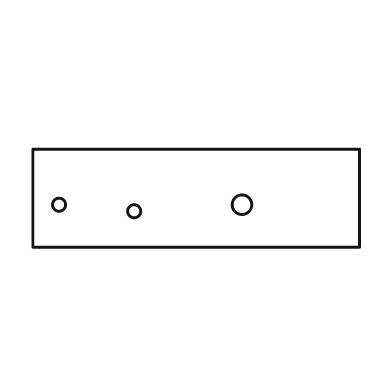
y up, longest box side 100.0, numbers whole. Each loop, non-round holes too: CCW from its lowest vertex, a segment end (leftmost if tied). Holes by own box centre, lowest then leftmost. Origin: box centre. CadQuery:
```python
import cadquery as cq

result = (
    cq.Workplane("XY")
    .moveTo(-50.0, -15.0)
    .lineTo(50.0, -15.0)
    .lineTo(50.0, 15.0)
    .lineTo(-50.0, 15.0)
    .close()
    .moveTo(-19.0, -4.0)
    .circle(2.0)
    .moveTo(-42.0, -2.0)
    .circle(2.0)
    .moveTo(14.0, -2.0)
    .circle(3.0)
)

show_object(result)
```